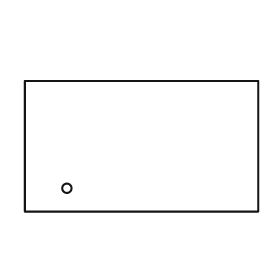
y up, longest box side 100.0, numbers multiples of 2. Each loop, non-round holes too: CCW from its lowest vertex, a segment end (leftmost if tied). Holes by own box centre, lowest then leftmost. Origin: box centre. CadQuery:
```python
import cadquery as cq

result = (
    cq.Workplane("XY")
    .moveTo(-50.0, -28.0)
    .lineTo(50.0, -28.0)
    .lineTo(50.0, 28.0)
    .lineTo(-50.0, 28.0)
    .close()
    .moveTo(-32.0, -18.0)
    .circle(2.0)
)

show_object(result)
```